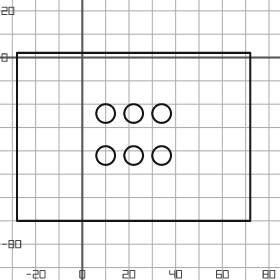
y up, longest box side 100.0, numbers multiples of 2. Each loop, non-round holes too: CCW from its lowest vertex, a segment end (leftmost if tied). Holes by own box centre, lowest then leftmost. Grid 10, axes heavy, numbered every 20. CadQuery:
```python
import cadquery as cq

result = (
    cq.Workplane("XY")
    .moveTo(-28.0, -70.0)
    .lineTo(72.0, -70.0)
    .lineTo(72.0, 2.0)
    .lineTo(-28.0, 2.0)
    .close()
    .moveTo(10.0, -42.0)
    .circle(4.0)
    .moveTo(22.0, -42.0)
    .circle(4.0)
    .moveTo(34.0, -42.0)
    .circle(4.0)
    .moveTo(10.0, -24.0)
    .circle(4.0)
    .moveTo(22.0, -24.0)
    .circle(4.0)
    .moveTo(34.0, -24.0)
    .circle(4.0)
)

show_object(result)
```